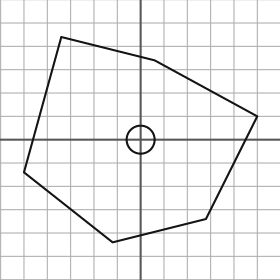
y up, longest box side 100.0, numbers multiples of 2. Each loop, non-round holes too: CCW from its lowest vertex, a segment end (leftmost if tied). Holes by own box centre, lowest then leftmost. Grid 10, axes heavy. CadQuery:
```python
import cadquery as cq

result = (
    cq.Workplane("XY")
    .moveTo(-12.0, -44.0)
    .lineTo(28.0, -34.0)
    .lineTo(50.0, 10.0)
    .lineTo(6.0, 34.0)
    .lineTo(-34.0, 44.0)
    .lineTo(-50.0, -14.0)
    .close()
    .moveTo(0.0, 0.0)
    .circle(6.0)
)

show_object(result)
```